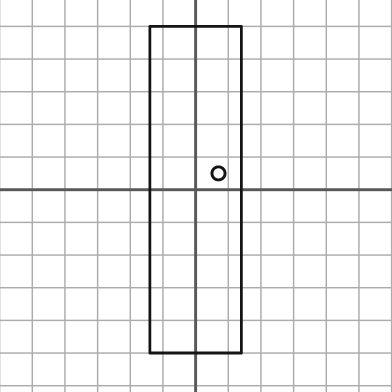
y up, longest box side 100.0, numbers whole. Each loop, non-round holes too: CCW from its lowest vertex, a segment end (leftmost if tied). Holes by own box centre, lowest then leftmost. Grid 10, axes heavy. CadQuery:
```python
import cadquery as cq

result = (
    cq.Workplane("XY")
    .moveTo(-14.0, -50.0)
    .lineTo(14.0, -50.0)
    .lineTo(14.0, 50.0)
    .lineTo(-14.0, 50.0)
    .close()
    .moveTo(7.0, 5.0)
    .circle(2.0)
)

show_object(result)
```